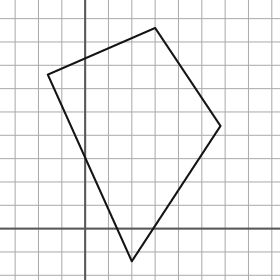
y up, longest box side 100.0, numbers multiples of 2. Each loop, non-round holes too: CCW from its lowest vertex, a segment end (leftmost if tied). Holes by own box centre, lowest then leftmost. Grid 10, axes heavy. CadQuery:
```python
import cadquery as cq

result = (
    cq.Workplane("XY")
    .moveTo(20.0, -14.0)
    .lineTo(58.0, 44.0)
    .lineTo(30.0, 86.0)
    .lineTo(-16.0, 66.0)
    .close()
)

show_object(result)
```